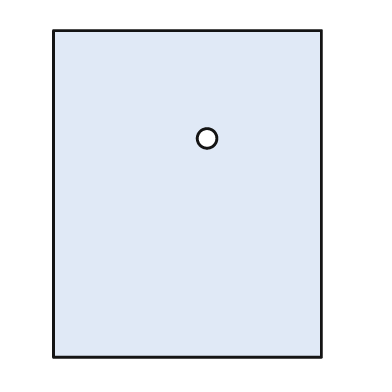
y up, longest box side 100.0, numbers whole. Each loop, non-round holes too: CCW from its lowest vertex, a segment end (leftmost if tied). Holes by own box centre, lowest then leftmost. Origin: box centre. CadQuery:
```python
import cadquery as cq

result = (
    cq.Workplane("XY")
    .moveTo(-41.0, -50.0)
    .lineTo(41.0, -50.0)
    .lineTo(41.0, 50.0)
    .lineTo(-41.0, 50.0)
    .close()
    .moveTo(6.0, 17.0)
    .circle(3.0)
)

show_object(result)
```